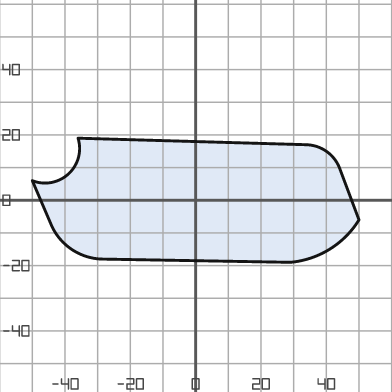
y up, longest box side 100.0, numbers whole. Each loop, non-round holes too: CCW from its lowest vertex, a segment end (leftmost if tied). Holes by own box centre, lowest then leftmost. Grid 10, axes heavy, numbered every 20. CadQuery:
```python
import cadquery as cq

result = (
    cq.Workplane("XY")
    .moveTo(29.0, -19.0)
    .threePointArc((41.0, -15.0), (50.0, -6.0))
    .lineTo(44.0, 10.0)
    .threePointArc((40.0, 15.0), (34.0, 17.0))
    .lineTo(-36.0, 19.0)
    .threePointArc((-39.0, 8.0), (-50.0, 6.0))
    .lineTo(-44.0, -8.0)
    .threePointArc((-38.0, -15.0), (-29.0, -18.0))
    .close()
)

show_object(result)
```